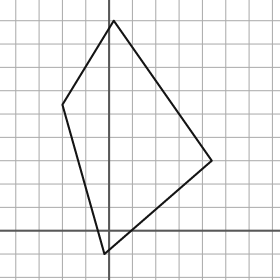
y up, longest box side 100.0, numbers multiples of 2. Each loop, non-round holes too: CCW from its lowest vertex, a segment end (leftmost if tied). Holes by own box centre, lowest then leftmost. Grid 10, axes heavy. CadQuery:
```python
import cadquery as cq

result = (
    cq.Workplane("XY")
    .moveTo(-2.0, -10.0)
    .lineTo(44.0, 30.0)
    .lineTo(2.0, 90.0)
    .lineTo(-20.0, 54.0)
    .close()
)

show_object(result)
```